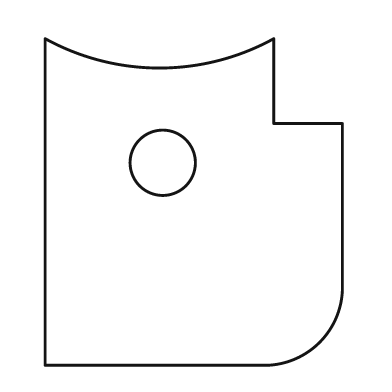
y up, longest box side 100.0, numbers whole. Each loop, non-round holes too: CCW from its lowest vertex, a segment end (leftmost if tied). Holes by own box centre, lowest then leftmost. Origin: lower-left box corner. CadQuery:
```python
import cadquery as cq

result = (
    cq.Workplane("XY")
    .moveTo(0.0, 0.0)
    .lineTo(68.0, 0.0)
    .threePointArc((84.0, 7.0), (91.0, 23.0))
    .lineTo(91.0, 74.0)
    .lineTo(70.0, 74.0)
    .lineTo(70.0, 100.0)
    .threePointArc((35.0, 91.0), (0.0, 100.0))
    .close()
    .moveTo(36.0, 62.0)
    .circle(10.0)
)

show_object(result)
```